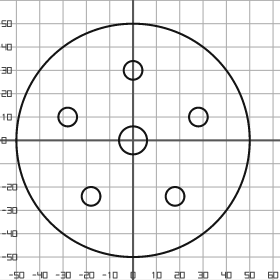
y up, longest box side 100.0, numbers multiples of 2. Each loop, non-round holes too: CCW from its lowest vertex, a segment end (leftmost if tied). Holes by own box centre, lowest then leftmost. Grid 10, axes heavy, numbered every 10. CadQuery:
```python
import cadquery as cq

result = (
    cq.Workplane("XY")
    .moveTo(0.0, 0.0)
    .circle(50.0)
    .moveTo(-18.0, -24.0)
    .circle(4.0)
    .moveTo(18.0, -24.0)
    .circle(4.0)
    .moveTo(0.0, 0.0)
    .circle(6.0)
    .moveTo(-28.0, 10.0)
    .circle(4.0)
    .moveTo(28.0, 10.0)
    .circle(4.0)
    .moveTo(0.0, 30.0)
    .circle(4.0)
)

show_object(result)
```